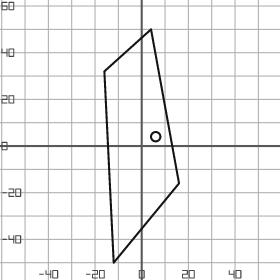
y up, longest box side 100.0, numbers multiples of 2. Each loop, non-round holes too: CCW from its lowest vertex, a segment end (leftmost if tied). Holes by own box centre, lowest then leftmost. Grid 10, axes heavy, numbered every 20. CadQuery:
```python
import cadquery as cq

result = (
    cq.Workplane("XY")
    .moveTo(-12.0, -50.0)
    .lineTo(16.0, -16.0)
    .lineTo(4.0, 50.0)
    .lineTo(-16.0, 32.0)
    .close()
    .moveTo(6.0, 4.0)
    .circle(2.0)
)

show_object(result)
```